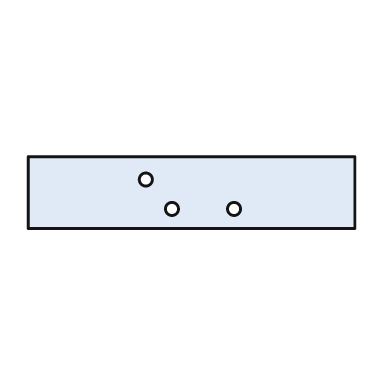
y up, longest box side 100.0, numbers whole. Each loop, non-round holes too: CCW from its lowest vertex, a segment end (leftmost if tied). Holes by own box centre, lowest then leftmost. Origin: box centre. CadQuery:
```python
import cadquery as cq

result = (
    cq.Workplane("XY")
    .moveTo(-50.0, -11.0)
    .lineTo(50.0, -11.0)
    .lineTo(50.0, 11.0)
    .lineTo(-50.0, 11.0)
    .close()
    .moveTo(-6.0, -5.0)
    .circle(2.0)
    .moveTo(13.0, -5.0)
    .circle(2.0)
    .moveTo(-14.0, 4.0)
    .circle(2.0)
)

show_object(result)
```